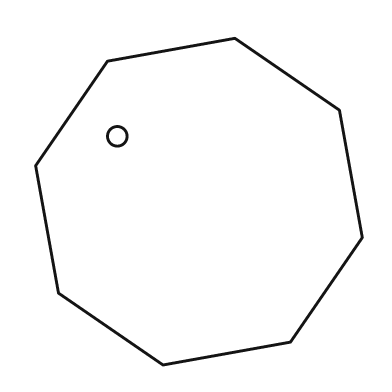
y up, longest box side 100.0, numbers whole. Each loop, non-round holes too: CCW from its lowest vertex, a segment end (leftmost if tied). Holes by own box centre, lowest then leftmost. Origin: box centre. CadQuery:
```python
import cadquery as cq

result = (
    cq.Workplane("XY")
    .moveTo(-11.0, -50.0)
    .lineTo(28.0, -43.0)
    .lineTo(50.0, -11.0)
    .lineTo(43.0, 28.0)
    .lineTo(11.0, 50.0)
    .lineTo(-28.0, 43.0)
    .lineTo(-50.0, 11.0)
    .lineTo(-43.0, -28.0)
    .close()
    .moveTo(-25.0, 20.0)
    .circle(3.0)
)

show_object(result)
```